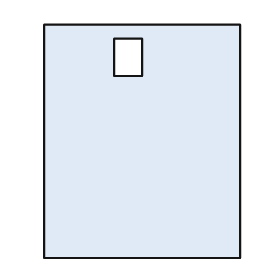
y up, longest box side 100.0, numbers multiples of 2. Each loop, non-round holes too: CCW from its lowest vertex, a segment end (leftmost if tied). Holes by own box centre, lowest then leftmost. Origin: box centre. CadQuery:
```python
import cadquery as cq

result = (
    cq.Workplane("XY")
    .moveTo(-42.0, -50.0)
    .lineTo(42.0, -50.0)
    .lineTo(42.0, 50.0)
    .lineTo(-42.0, 50.0)
    .close()
    .moveTo(-12.0, 28.0)
    .lineTo(0.0, 28.0)
    .lineTo(0.0, 44.0)
    .lineTo(-12.0, 44.0)
    .close()
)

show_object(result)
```